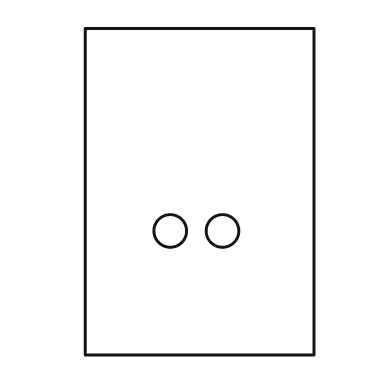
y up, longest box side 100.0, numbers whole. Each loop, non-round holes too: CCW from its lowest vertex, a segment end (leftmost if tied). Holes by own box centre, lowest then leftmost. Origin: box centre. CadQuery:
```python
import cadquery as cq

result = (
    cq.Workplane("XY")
    .moveTo(-35.0, -50.0)
    .lineTo(35.0, -50.0)
    .lineTo(35.0, 50.0)
    .lineTo(-35.0, 50.0)
    .close()
    .moveTo(-9.0, -12.0)
    .circle(5.0)
    .moveTo(7.0, -12.0)
    .circle(5.0)
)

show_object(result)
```